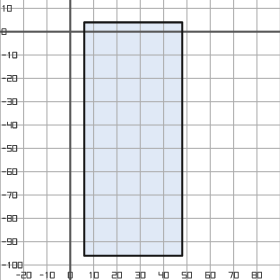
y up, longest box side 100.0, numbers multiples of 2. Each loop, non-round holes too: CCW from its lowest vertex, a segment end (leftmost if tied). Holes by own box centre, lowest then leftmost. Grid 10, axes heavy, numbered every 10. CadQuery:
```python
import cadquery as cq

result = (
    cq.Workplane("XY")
    .moveTo(6.0, -96.0)
    .lineTo(48.0, -96.0)
    .lineTo(48.0, 4.0)
    .lineTo(6.0, 4.0)
    .close()
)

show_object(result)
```